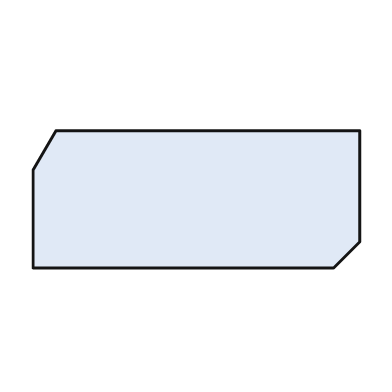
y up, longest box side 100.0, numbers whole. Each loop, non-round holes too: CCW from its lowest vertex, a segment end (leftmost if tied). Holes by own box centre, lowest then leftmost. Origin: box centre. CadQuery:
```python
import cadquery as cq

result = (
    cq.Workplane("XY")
    .moveTo(-50.0, -21.0)
    .lineTo(42.0, -21.0)
    .lineTo(50.0, -13.0)
    .lineTo(50.0, 21.0)
    .lineTo(-43.0, 21.0)
    .lineTo(-50.0, 9.0)
    .close()
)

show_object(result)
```